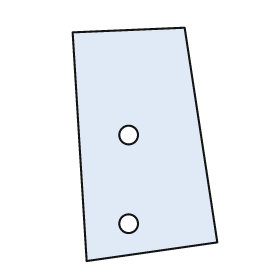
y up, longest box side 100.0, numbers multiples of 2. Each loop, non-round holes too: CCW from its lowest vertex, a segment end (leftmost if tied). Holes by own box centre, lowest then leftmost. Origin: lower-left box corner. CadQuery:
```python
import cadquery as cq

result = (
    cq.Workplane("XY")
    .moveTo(6.0, 0.0)
    .lineTo(62.0, 8.0)
    .lineTo(48.0, 100.0)
    .lineTo(0.0, 98.0)
    .close()
    .moveTo(24.0, 16.0)
    .circle(4.0)
    .moveTo(24.0, 54.0)
    .circle(4.0)
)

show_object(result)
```